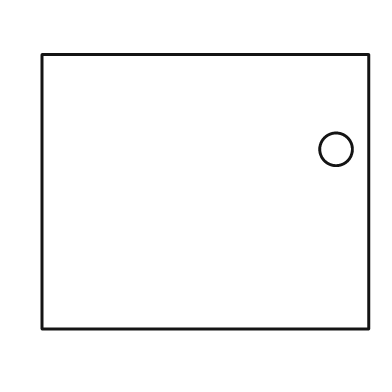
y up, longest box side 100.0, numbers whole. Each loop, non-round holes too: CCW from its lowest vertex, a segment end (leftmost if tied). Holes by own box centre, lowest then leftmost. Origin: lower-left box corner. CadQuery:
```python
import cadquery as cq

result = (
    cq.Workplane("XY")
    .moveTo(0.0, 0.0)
    .lineTo(100.0, 0.0)
    .lineTo(100.0, 84.0)
    .lineTo(0.0, 84.0)
    .close()
    .moveTo(90.0, 55.0)
    .circle(5.0)
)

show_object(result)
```